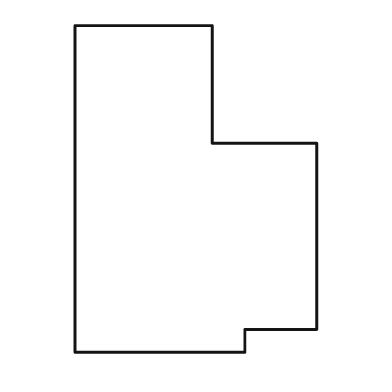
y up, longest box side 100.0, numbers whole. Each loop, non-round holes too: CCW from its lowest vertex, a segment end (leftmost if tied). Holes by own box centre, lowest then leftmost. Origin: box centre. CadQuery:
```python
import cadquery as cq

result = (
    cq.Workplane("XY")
    .moveTo(-37.0, -50.0)
    .lineTo(15.0, -50.0)
    .lineTo(15.0, -43.0)
    .lineTo(37.0, -43.0)
    .lineTo(37.0, 14.0)
    .lineTo(5.0, 14.0)
    .lineTo(5.0, 50.0)
    .lineTo(-37.0, 50.0)
    .close()
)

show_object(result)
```